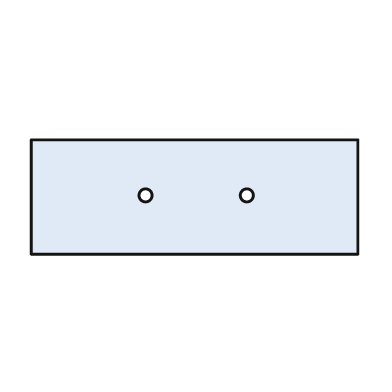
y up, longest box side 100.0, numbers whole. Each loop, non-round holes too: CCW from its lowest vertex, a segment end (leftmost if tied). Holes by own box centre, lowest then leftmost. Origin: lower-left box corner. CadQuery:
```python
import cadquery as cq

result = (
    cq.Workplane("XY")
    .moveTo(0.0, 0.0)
    .lineTo(100.0, 0.0)
    .lineTo(100.0, 35.0)
    .lineTo(0.0, 35.0)
    .close()
    .moveTo(35.0, 18.0)
    .circle(2.0)
    .moveTo(66.0, 18.0)
    .circle(2.0)
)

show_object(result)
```